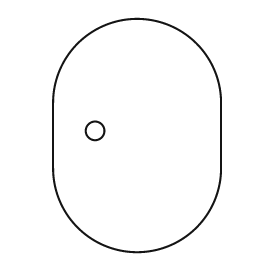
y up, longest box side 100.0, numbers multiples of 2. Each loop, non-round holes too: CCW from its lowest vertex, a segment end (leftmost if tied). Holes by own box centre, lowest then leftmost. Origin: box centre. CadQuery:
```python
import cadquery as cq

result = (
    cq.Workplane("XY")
    .moveTo(-36.0, -14.0)
    .threePointArc((0.0, -50.0), (36.0, -14.0))
    .lineTo(36.0, 14.0)
    .threePointArc((0.0, 50.0), (-36.0, 14.0))
    .close()
    .moveTo(-18.0, 2.0)
    .circle(4.0)
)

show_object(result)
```